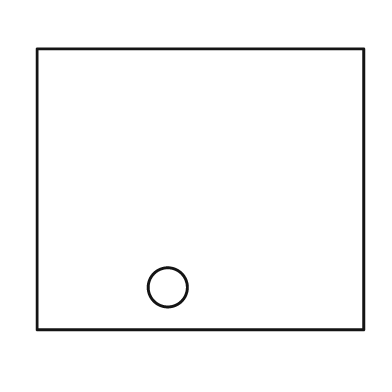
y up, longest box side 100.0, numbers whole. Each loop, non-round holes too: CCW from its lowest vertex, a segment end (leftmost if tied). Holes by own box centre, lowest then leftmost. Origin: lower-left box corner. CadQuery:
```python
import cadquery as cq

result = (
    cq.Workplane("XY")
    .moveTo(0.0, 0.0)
    .lineTo(100.0, 0.0)
    .lineTo(100.0, 86.0)
    .lineTo(0.0, 86.0)
    .close()
    .moveTo(40.0, 13.0)
    .circle(6.0)
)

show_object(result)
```